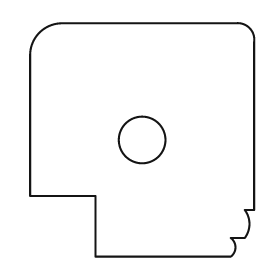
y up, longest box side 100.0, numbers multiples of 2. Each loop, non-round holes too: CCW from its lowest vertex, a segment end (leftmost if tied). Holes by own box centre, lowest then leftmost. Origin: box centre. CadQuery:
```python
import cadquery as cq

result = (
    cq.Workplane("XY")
    .moveTo(-20.0, -50.0)
    .lineTo(38.0, -50.0)
    .threePointArc((40.0, -46.0), (38.0, -42.0))
    .lineTo(44.0, -42.0)
    .threePointArc((46.0, -36.0), (44.0, -30.0))
    .lineTo(48.0, -30.0)
    .lineTo(48.0, 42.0)
    .threePointArc((46.0, 48.0), (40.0, 50.0))
    .lineTo(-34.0, 50.0)
    .threePointArc((-44.0, 46.0), (-48.0, 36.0))
    .lineTo(-48.0, -24.0)
    .lineTo(-20.0, -24.0)
    .close()
    .moveTo(0.0, 0.0)
    .circle(10.0)
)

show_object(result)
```